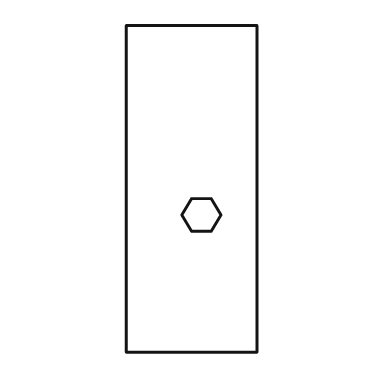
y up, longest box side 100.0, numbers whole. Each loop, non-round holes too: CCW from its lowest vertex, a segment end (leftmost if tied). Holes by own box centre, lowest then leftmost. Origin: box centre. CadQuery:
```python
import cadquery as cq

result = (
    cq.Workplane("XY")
    .moveTo(-20.0, -50.0)
    .lineTo(20.0, -50.0)
    .lineTo(20.0, 50.0)
    .lineTo(-20.0, 50.0)
    .close()
    .moveTo(0.0, -13.0)
    .lineTo(6.0, -13.0)
    .lineTo(9.0, -8.0)
    .lineTo(6.0, -3.0)
    .lineTo(0.0, -3.0)
    .lineTo(-3.0, -8.0)
    .close()
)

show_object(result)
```